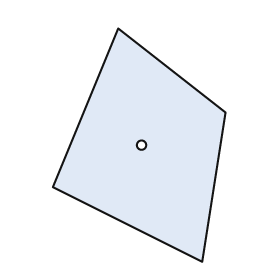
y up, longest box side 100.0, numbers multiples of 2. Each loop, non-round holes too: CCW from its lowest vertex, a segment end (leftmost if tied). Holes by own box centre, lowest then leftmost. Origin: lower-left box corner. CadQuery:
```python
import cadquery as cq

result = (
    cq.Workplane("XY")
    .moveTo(64.0, 0.0)
    .lineTo(74.0, 64.0)
    .lineTo(28.0, 100.0)
    .lineTo(0.0, 32.0)
    .close()
    .moveTo(38.0, 50.0)
    .circle(2.0)
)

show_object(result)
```